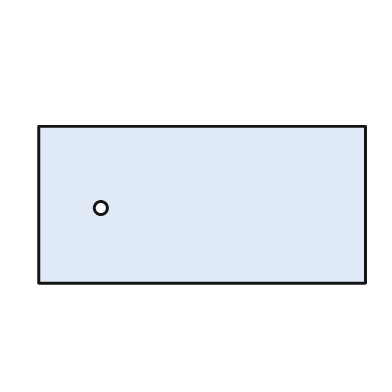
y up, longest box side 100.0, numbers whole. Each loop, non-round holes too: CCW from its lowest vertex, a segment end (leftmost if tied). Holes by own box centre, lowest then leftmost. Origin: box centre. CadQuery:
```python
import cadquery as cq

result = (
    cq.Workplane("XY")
    .moveTo(-50.0, -24.0)
    .lineTo(50.0, -24.0)
    .lineTo(50.0, 24.0)
    .lineTo(-50.0, 24.0)
    .close()
    .moveTo(-31.0, -1.0)
    .circle(2.0)
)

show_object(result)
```